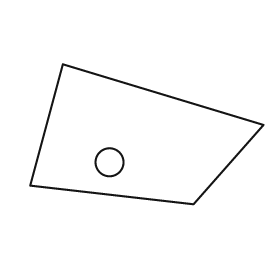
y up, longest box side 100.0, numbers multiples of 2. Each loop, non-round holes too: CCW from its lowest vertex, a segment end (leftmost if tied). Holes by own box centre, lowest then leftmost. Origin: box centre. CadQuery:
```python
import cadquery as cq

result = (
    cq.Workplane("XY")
    .moveTo(20.0, -30.0)
    .lineTo(50.0, 4.0)
    .lineTo(-36.0, 30.0)
    .lineTo(-50.0, -22.0)
    .close()
    .moveTo(-16.0, -12.0)
    .circle(6.0)
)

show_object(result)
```